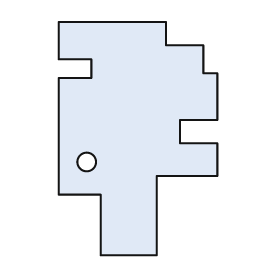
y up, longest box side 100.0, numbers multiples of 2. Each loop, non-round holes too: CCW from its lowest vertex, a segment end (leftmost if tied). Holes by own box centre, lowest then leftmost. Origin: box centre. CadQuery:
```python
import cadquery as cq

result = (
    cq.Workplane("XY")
    .moveTo(-16.0, -50.0)
    .lineTo(8.0, -50.0)
    .lineTo(8.0, -16.0)
    .lineTo(34.0, -16.0)
    .lineTo(34.0, -2.0)
    .lineTo(18.0, -2.0)
    .lineTo(18.0, 8.0)
    .lineTo(34.0, 8.0)
    .lineTo(34.0, 28.0)
    .lineTo(28.0, 28.0)
    .lineTo(28.0, 40.0)
    .lineTo(12.0, 40.0)
    .lineTo(12.0, 50.0)
    .lineTo(-34.0, 50.0)
    .lineTo(-34.0, 34.0)
    .lineTo(-20.0, 34.0)
    .lineTo(-20.0, 26.0)
    .lineTo(-34.0, 26.0)
    .lineTo(-34.0, -24.0)
    .lineTo(-16.0, -24.0)
    .close()
    .moveTo(-22.0, -10.0)
    .circle(4.0)
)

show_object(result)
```